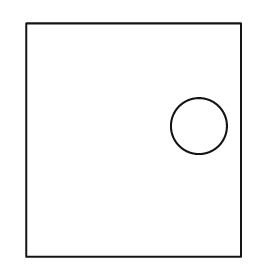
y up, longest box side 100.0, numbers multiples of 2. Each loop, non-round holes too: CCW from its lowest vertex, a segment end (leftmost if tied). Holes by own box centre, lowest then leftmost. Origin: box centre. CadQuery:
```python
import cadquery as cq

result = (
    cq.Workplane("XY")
    .moveTo(-46.0, -50.0)
    .lineTo(46.0, -50.0)
    .lineTo(46.0, 50.0)
    .lineTo(-46.0, 50.0)
    .close()
    .moveTo(28.0, 6.0)
    .circle(12.0)
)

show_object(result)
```